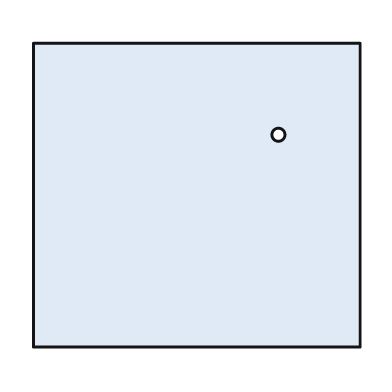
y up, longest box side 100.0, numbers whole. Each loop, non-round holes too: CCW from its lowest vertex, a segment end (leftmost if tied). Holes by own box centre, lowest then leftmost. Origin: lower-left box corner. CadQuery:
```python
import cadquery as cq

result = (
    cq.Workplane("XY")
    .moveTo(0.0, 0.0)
    .lineTo(100.0, 0.0)
    .lineTo(100.0, 93.0)
    .lineTo(0.0, 93.0)
    .close()
    .moveTo(75.0, 65.0)
    .circle(2.0)
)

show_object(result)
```